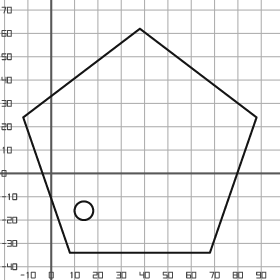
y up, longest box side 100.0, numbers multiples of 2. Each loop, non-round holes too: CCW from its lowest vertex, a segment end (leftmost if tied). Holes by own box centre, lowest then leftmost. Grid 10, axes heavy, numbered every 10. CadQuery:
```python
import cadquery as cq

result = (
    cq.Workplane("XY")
    .moveTo(8.0, -34.0)
    .lineTo(68.0, -34.0)
    .lineTo(88.0, 24.0)
    .lineTo(38.0, 62.0)
    .lineTo(-12.0, 24.0)
    .close()
    .moveTo(14.0, -16.0)
    .circle(4.0)
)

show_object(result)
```